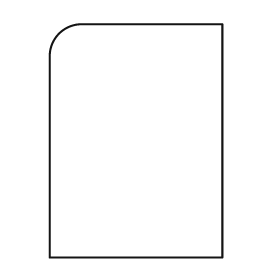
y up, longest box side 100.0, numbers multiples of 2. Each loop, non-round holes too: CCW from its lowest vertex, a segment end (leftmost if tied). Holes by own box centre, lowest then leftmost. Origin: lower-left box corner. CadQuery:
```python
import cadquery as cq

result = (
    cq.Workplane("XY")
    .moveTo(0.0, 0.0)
    .lineTo(74.0, 0.0)
    .lineTo(74.0, 100.0)
    .lineTo(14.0, 100.0)
    .threePointArc((4.0, 96.0), (0.0, 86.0))
    .close()
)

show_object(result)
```